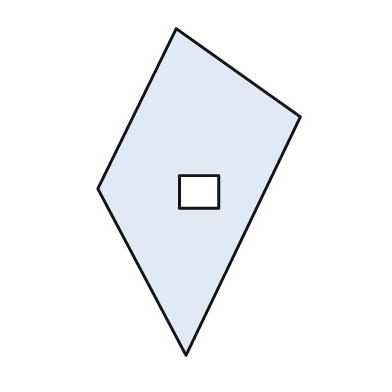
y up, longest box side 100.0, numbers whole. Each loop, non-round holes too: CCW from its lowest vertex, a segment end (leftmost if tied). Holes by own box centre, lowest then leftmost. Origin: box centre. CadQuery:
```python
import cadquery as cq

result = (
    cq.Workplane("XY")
    .moveTo(-4.0, -50.0)
    .lineTo(31.0, 23.0)
    .lineTo(-7.0, 50.0)
    .lineTo(-31.0, 1.0)
    .close()
    .moveTo(-6.0, -5.0)
    .lineTo(6.0, -5.0)
    .lineTo(6.0, 5.0)
    .lineTo(-6.0, 5.0)
    .close()
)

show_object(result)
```